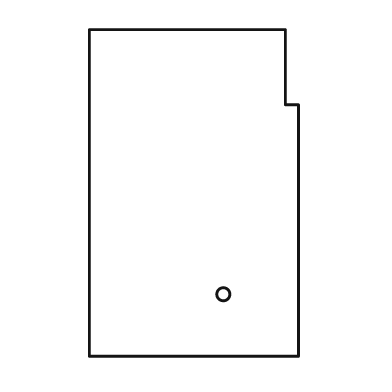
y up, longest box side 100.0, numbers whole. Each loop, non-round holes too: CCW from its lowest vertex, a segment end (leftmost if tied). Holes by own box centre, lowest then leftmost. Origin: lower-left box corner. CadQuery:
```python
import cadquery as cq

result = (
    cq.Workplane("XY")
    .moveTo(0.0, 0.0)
    .lineTo(64.0, 0.0)
    .lineTo(64.0, 77.0)
    .lineTo(60.0, 77.0)
    .lineTo(60.0, 100.0)
    .lineTo(0.0, 100.0)
    .close()
    .moveTo(41.0, 19.0)
    .circle(2.0)
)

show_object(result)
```